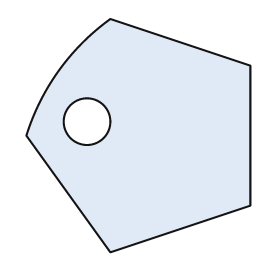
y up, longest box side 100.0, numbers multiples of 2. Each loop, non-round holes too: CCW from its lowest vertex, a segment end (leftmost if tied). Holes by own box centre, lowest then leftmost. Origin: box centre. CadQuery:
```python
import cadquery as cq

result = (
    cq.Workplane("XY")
    .moveTo(-12.0, -50.0)
    .lineTo(48.0, -30.0)
    .lineTo(48.0, 30.0)
    .lineTo(-12.0, 50.0)
    .threePointArc((-34.0, 28.0), (-48.0, 0.0))
    .close()
    .moveTo(-22.0, 6.0)
    .circle(10.0)
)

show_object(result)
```